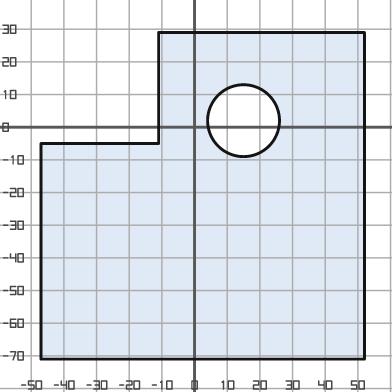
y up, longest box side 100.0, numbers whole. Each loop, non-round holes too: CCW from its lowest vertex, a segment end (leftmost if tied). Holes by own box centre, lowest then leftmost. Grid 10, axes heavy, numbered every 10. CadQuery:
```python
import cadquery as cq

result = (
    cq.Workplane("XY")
    .moveTo(-47.0, -71.0)
    .lineTo(52.0, -71.0)
    .lineTo(52.0, 29.0)
    .lineTo(-11.0, 29.0)
    .lineTo(-11.0, -5.0)
    .lineTo(-47.0, -5.0)
    .close()
    .moveTo(15.0, 2.0)
    .circle(11.0)
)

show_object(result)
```